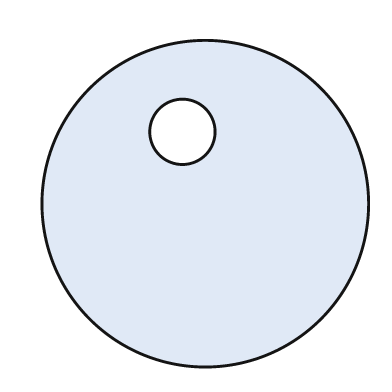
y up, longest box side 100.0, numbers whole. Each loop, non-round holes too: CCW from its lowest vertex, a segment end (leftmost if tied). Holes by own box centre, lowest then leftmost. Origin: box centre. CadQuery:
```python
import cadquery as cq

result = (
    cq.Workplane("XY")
    .moveTo(0.0, 0.0)
    .circle(50.0)
    .moveTo(-7.0, 22.0)
    .circle(10.0)
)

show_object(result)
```